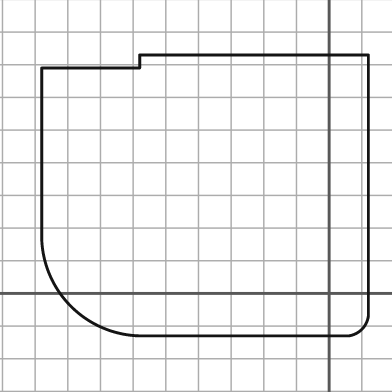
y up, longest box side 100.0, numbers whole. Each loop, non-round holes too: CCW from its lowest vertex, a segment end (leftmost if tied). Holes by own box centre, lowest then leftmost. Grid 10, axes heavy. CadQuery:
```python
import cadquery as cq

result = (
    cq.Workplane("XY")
    .moveTo(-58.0, -13.0)
    .lineTo(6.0, -13.0)
    .threePointArc((10.0, -11.0), (12.0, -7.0))
    .lineTo(12.0, 73.0)
    .lineTo(-58.0, 73.0)
    .lineTo(-58.0, 69.0)
    .lineTo(-88.0, 69.0)
    .lineTo(-88.0, 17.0)
    .threePointArc((-79.0, -4.0), (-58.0, -13.0))
    .close()
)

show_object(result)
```